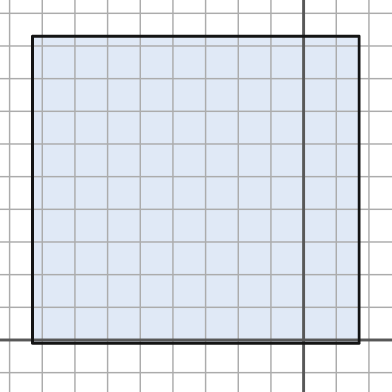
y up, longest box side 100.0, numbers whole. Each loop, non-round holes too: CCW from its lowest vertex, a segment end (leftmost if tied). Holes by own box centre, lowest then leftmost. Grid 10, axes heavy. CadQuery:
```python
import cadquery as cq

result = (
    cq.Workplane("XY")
    .moveTo(-83.0, -1.0)
    .lineTo(17.0, -1.0)
    .lineTo(17.0, 93.0)
    .lineTo(-83.0, 93.0)
    .close()
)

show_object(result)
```